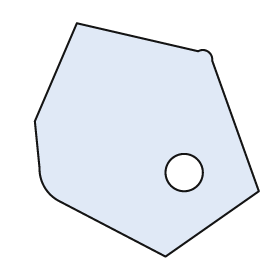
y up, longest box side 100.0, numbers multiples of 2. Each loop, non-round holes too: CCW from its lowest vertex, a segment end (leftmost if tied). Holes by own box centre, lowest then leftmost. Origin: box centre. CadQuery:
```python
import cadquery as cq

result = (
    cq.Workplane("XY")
    .moveTo(8.0, -50.0)
    .lineTo(48.0, -22.0)
    .lineTo(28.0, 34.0)
    .threePointArc((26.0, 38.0), (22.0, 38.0))
    .lineTo(-30.0, 50.0)
    .lineTo(-48.0, 8.0)
    .lineTo(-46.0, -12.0)
    .threePointArc((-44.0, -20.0), (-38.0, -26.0))
    .close()
    .moveTo(16.0, -14.0)
    .circle(8.0)
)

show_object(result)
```